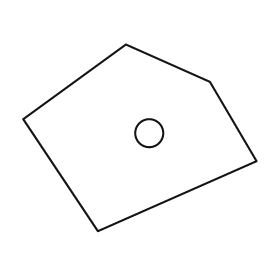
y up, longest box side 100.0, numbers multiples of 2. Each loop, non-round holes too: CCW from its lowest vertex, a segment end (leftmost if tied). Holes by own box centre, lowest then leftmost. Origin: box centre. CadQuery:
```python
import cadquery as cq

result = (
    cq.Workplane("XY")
    .moveTo(-18.0, -40.0)
    .lineTo(50.0, -10.0)
    .lineTo(30.0, 24.0)
    .lineTo(-6.0, 40.0)
    .lineTo(-50.0, 8.0)
    .close()
    .moveTo(4.0, 2.0)
    .circle(6.0)
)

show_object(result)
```